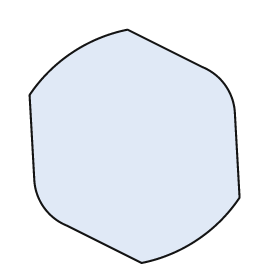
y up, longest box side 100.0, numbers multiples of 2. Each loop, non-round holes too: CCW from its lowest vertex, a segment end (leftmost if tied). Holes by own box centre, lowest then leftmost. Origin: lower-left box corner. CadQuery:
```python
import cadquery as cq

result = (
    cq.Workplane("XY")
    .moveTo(48.0, 0.0)
    .threePointArc((72.0, 10.0), (90.0, 28.0))
    .lineTo(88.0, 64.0)
    .threePointArc((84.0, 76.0), (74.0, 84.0))
    .lineTo(42.0, 100.0)
    .threePointArc((18.0, 90.0), (0.0, 72.0))
    .lineTo(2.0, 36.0)
    .threePointArc((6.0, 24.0), (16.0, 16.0))
    .close()
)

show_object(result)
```